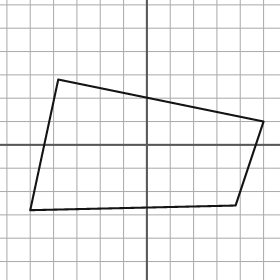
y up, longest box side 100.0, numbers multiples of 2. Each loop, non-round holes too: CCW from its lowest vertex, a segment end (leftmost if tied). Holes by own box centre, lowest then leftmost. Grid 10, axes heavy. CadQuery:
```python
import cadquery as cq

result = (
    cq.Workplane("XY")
    .moveTo(-50.0, -28.0)
    .lineTo(38.0, -26.0)
    .lineTo(50.0, 10.0)
    .lineTo(-38.0, 28.0)
    .close()
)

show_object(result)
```